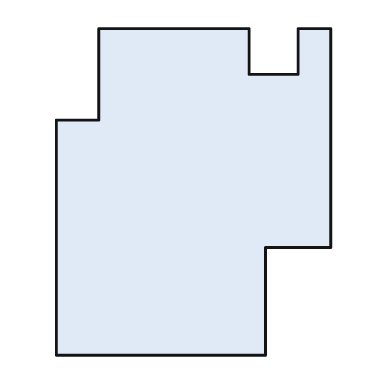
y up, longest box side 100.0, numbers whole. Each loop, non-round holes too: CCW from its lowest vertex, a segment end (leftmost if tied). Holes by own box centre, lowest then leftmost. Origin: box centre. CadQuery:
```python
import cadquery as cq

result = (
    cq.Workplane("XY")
    .moveTo(-42.0, -50.0)
    .lineTo(22.0, -50.0)
    .lineTo(22.0, -17.0)
    .lineTo(42.0, -17.0)
    .lineTo(42.0, 50.0)
    .lineTo(32.0, 50.0)
    .lineTo(32.0, 36.0)
    .lineTo(17.0, 36.0)
    .lineTo(17.0, 50.0)
    .lineTo(-29.0, 50.0)
    .lineTo(-29.0, 22.0)
    .lineTo(-42.0, 22.0)
    .close()
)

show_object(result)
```